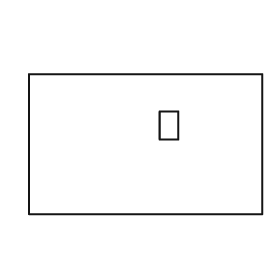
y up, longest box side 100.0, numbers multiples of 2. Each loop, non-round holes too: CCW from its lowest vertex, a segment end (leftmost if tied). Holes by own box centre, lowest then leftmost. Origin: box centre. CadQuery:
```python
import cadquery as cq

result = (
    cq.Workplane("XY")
    .moveTo(-50.0, -30.0)
    .lineTo(50.0, -30.0)
    .lineTo(50.0, 30.0)
    .lineTo(-50.0, 30.0)
    .close()
    .moveTo(6.0, 2.0)
    .lineTo(14.0, 2.0)
    .lineTo(14.0, 14.0)
    .lineTo(6.0, 14.0)
    .close()
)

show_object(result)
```